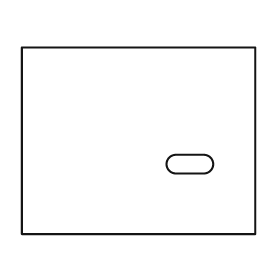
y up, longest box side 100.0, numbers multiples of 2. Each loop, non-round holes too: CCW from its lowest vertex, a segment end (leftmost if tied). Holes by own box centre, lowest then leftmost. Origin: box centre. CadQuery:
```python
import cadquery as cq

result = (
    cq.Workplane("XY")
    .moveTo(-50.0, -40.0)
    .lineTo(50.0, -40.0)
    .lineTo(50.0, 40.0)
    .lineTo(-50.0, 40.0)
    .close()
    .moveTo(16.0, -14.0)
    .lineTo(28.0, -14.0)
    .threePointArc((32.0, -10.0), (28.0, -6.0))
    .lineTo(16.0, -6.0)
    .threePointArc((12.0, -10.0), (16.0, -14.0))
    .close()
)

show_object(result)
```